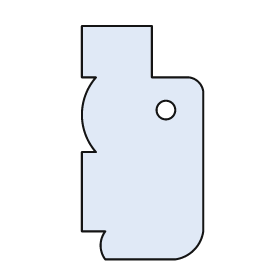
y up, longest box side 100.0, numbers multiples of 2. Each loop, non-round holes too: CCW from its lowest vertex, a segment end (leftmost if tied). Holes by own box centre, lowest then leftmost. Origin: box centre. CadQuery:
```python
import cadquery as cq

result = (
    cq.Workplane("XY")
    .moveTo(-16.0, -50.0)
    .lineTo(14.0, -50.0)
    .threePointArc((22.0, -46.0), (26.0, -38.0))
    .lineTo(26.0, 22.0)
    .threePointArc((24.0, 26.0), (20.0, 28.0))
    .lineTo(4.0, 28.0)
    .lineTo(4.0, 50.0)
    .lineTo(-26.0, 50.0)
    .lineTo(-26.0, 28.0)
    .lineTo(-20.0, 28.0)
    .threePointArc((-26.0, 12.0), (-20.0, -4.0))
    .lineTo(-26.0, -4.0)
    .lineTo(-26.0, -38.0)
    .lineTo(-16.0, -38.0)
    .threePointArc((-18.0, -44.0), (-16.0, -50.0))
    .close()
    .moveTo(10.0, 14.0)
    .circle(4.0)
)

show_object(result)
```